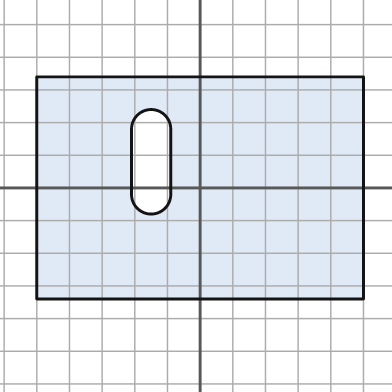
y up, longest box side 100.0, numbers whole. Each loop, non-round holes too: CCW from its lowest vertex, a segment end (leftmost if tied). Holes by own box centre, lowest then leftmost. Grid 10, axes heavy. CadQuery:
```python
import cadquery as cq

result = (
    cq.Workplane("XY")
    .moveTo(-50.0, -34.0)
    .lineTo(50.0, -34.0)
    .lineTo(50.0, 34.0)
    .lineTo(-50.0, 34.0)
    .close()
    .moveTo(-21.0, -2.0)
    .threePointArc((-15.0, -8.0), (-9.0, -2.0))
    .lineTo(-9.0, 18.0)
    .threePointArc((-15.0, 24.0), (-21.0, 18.0))
    .close()
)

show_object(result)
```